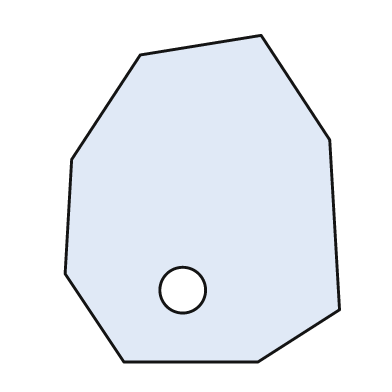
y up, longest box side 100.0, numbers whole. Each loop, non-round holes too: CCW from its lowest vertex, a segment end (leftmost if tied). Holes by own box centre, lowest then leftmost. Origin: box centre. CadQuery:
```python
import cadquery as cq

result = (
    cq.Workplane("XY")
    .moveTo(-24.0, -50.0)
    .lineTo(17.0, -50.0)
    .lineTo(42.0, -34.0)
    .lineTo(39.0, 18.0)
    .lineTo(18.0, 50.0)
    .lineTo(-19.0, 44.0)
    .lineTo(-40.0, 12.0)
    .lineTo(-42.0, -23.0)
    .close()
    .moveTo(-6.0, -28.0)
    .circle(7.0)
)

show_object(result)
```